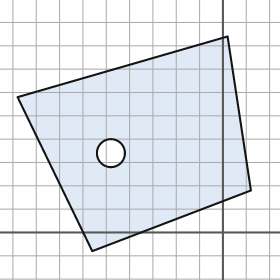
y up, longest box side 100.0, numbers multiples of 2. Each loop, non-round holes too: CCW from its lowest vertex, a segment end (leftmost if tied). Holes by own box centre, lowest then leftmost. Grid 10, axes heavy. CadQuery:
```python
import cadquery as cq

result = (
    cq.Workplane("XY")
    .moveTo(-56.0, -8.0)
    .lineTo(12.0, 18.0)
    .lineTo(2.0, 84.0)
    .lineTo(-88.0, 58.0)
    .close()
    .moveTo(-48.0, 34.0)
    .circle(6.0)
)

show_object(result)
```